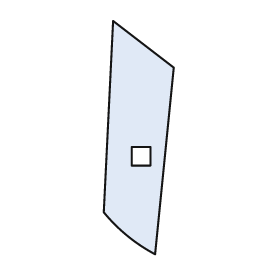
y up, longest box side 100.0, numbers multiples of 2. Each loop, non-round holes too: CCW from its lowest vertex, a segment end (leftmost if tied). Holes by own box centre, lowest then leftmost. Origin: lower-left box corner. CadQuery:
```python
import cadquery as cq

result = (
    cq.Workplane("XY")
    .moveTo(22.0, 0.0)
    .lineTo(30.0, 80.0)
    .lineTo(4.0, 100.0)
    .lineTo(0.0, 18.0)
    .threePointArc((10.0, 8.0), (22.0, 0.0))
    .close()
    .moveTo(12.0, 38.0)
    .lineTo(20.0, 38.0)
    .lineTo(20.0, 46.0)
    .lineTo(12.0, 46.0)
    .close()
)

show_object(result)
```